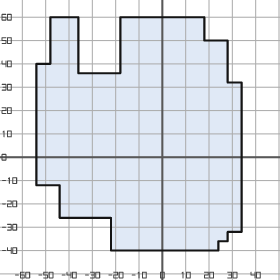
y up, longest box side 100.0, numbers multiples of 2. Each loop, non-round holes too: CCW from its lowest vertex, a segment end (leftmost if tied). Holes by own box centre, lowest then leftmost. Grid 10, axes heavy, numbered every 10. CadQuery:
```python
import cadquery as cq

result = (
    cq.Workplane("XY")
    .moveTo(-22.0, -40.0)
    .lineTo(24.0, -40.0)
    .lineTo(24.0, -36.0)
    .lineTo(28.0, -36.0)
    .lineTo(28.0, -32.0)
    .lineTo(34.0, -32.0)
    .lineTo(34.0, 32.0)
    .lineTo(28.0, 32.0)
    .lineTo(28.0, 50.0)
    .lineTo(18.0, 50.0)
    .lineTo(18.0, 60.0)
    .lineTo(-18.0, 60.0)
    .lineTo(-18.0, 36.0)
    .lineTo(-36.0, 36.0)
    .lineTo(-36.0, 60.0)
    .lineTo(-48.0, 60.0)
    .lineTo(-48.0, 40.0)
    .lineTo(-54.0, 40.0)
    .lineTo(-54.0, -12.0)
    .lineTo(-44.0, -12.0)
    .lineTo(-44.0, -26.0)
    .lineTo(-22.0, -26.0)
    .close()
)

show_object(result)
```